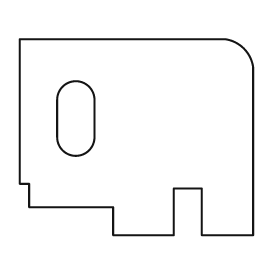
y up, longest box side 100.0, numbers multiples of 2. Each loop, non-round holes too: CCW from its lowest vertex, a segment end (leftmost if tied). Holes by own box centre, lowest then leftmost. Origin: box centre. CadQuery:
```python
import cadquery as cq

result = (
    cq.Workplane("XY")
    .moveTo(-10.0, -42.0)
    .lineTo(16.0, -42.0)
    .lineTo(16.0, -22.0)
    .lineTo(28.0, -22.0)
    .lineTo(28.0, -42.0)
    .lineTo(50.0, -42.0)
    .lineTo(50.0, 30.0)
    .threePointArc((46.0, 38.0), (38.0, 42.0))
    .lineTo(-50.0, 42.0)
    .lineTo(-50.0, -20.0)
    .lineTo(-46.0, -20.0)
    .lineTo(-46.0, -30.0)
    .lineTo(-10.0, -30.0)
    .close()
    .moveTo(-34.0, 0.0)
    .threePointArc((-26.0, -8.0), (-18.0, 0.0))
    .lineTo(-18.0, 16.0)
    .threePointArc((-26.0, 24.0), (-34.0, 16.0))
    .close()
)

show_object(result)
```